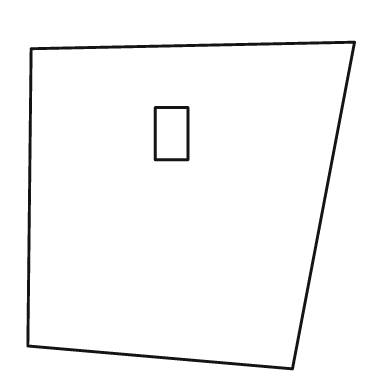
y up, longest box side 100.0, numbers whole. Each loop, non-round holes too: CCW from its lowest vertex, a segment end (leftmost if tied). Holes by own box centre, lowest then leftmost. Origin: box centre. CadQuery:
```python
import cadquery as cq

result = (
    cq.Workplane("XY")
    .moveTo(31.0, -50.0)
    .lineTo(50.0, 50.0)
    .lineTo(-49.0, 48.0)
    .lineTo(-50.0, -43.0)
    .close()
    .moveTo(-11.0, 14.0)
    .lineTo(-1.0, 14.0)
    .lineTo(-1.0, 30.0)
    .lineTo(-11.0, 30.0)
    .close()
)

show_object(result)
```